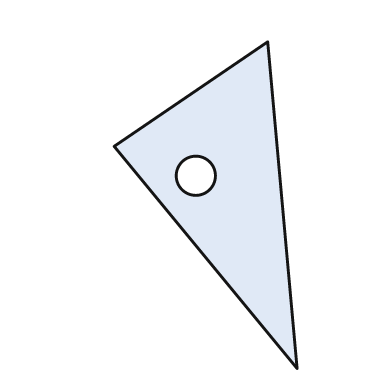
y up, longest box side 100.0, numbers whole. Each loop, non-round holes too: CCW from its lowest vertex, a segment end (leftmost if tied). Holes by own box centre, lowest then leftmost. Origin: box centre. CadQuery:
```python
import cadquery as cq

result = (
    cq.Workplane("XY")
    .moveTo(28.0, -50.0)
    .lineTo(19.0, 50.0)
    .lineTo(-28.0, 18.0)
    .close()
    .moveTo(-3.0, 9.0)
    .circle(6.0)
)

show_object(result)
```